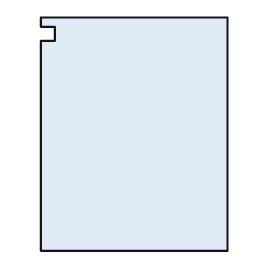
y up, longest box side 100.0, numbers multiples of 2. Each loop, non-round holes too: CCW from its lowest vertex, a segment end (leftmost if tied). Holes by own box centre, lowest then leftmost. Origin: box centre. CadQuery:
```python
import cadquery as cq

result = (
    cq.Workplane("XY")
    .moveTo(-40.0, -50.0)
    .lineTo(40.0, -50.0)
    .lineTo(40.0, 50.0)
    .lineTo(-40.0, 50.0)
    .lineTo(-40.0, 46.0)
    .lineTo(-34.0, 46.0)
    .lineTo(-34.0, 40.0)
    .lineTo(-40.0, 40.0)
    .close()
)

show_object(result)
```